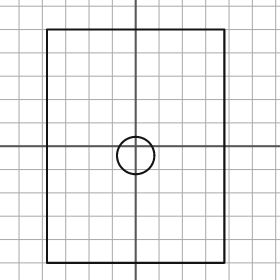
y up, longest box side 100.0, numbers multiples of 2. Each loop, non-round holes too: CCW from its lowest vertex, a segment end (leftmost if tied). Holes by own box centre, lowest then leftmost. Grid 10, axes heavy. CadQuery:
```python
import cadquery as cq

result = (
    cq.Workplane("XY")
    .moveTo(-38.0, -50.0)
    .lineTo(38.0, -50.0)
    .lineTo(38.0, 50.0)
    .lineTo(-38.0, 50.0)
    .close()
    .moveTo(0.0, -4.0)
    .circle(8.0)
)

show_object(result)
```